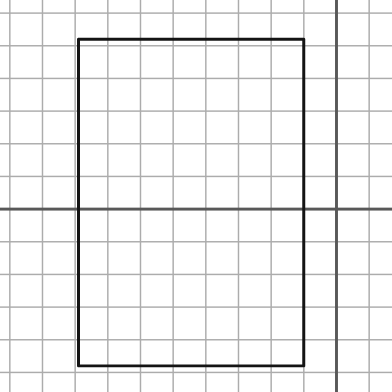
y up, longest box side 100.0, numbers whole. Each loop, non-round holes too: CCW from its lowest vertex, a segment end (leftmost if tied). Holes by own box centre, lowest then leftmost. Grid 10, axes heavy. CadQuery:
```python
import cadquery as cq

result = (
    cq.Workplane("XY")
    .moveTo(-79.0, -48.0)
    .lineTo(-10.0, -48.0)
    .lineTo(-10.0, 52.0)
    .lineTo(-79.0, 52.0)
    .close()
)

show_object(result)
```